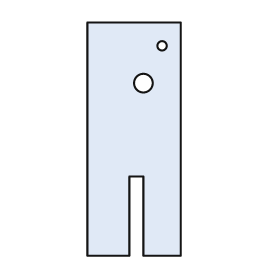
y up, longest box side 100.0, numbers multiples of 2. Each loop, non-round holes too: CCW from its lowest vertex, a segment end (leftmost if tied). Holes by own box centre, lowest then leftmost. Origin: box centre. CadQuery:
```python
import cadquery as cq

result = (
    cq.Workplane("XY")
    .moveTo(-20.0, -50.0)
    .lineTo(-2.0, -50.0)
    .lineTo(-2.0, -16.0)
    .lineTo(4.0, -16.0)
    .lineTo(4.0, -50.0)
    .lineTo(20.0, -50.0)
    .lineTo(20.0, 50.0)
    .lineTo(-20.0, 50.0)
    .close()
    .moveTo(4.0, 24.0)
    .circle(4.0)
    .moveTo(12.0, 40.0)
    .circle(2.0)
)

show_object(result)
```